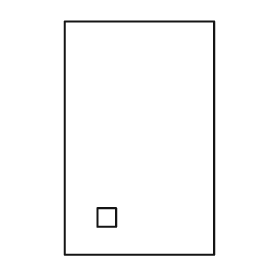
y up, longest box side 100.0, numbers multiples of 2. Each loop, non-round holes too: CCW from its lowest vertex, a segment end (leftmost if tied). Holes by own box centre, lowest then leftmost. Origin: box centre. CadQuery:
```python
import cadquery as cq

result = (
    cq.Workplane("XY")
    .moveTo(-32.0, -50.0)
    .lineTo(32.0, -50.0)
    .lineTo(32.0, 50.0)
    .lineTo(-32.0, 50.0)
    .close()
    .moveTo(-18.0, -38.0)
    .lineTo(-10.0, -38.0)
    .lineTo(-10.0, -30.0)
    .lineTo(-18.0, -30.0)
    .close()
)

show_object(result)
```